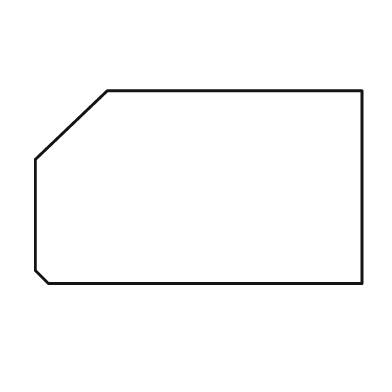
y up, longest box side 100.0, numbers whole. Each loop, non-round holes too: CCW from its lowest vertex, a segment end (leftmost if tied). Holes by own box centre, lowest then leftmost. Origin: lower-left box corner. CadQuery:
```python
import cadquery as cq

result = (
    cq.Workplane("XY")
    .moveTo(4.0, 0.0)
    .lineTo(100.0, 0.0)
    .lineTo(100.0, 59.0)
    .lineTo(22.0, 59.0)
    .lineTo(0.0, 38.0)
    .lineTo(0.0, 4.0)
    .close()
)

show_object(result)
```